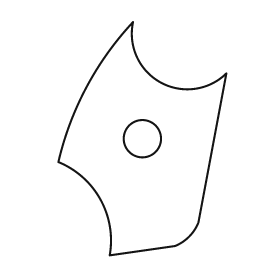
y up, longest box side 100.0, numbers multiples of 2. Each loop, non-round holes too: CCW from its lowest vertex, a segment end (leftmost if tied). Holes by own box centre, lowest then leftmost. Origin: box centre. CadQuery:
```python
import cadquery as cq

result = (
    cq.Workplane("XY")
    .moveTo(-14.0, -50.0)
    .lineTo(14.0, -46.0)
    .threePointArc((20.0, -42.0), (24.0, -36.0))
    .lineTo(36.0, 28.0)
    .threePointArc((8.0, 24.0), (-4.0, 50.0))
    .threePointArc((-24.0, 22.0), (-36.0, -10.0))
    .threePointArc((-18.0, -26.0), (-14.0, -50.0))
    .close()
    .moveTo(0.0, 0.0)
    .circle(8.0)
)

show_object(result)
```